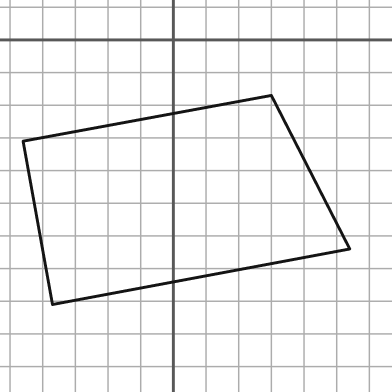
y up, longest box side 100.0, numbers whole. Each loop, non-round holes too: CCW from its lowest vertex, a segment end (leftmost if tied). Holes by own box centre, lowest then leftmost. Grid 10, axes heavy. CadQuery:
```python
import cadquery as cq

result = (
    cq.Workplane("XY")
    .moveTo(-37.0, -81.0)
    .lineTo(54.0, -64.0)
    .lineTo(30.0, -17.0)
    .lineTo(-46.0, -31.0)
    .close()
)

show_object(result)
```